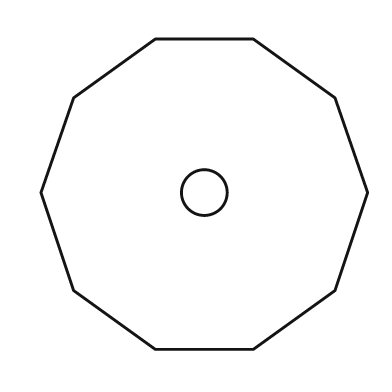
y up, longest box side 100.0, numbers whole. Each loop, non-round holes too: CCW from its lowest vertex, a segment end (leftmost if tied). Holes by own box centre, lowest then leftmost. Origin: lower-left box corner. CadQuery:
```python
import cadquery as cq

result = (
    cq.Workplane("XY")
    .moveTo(35.0, 0.0)
    .lineTo(65.0, 0.0)
    .lineTo(90.0, 18.0)
    .lineTo(100.0, 48.0)
    .lineTo(90.0, 77.0)
    .lineTo(65.0, 95.0)
    .lineTo(35.0, 95.0)
    .lineTo(10.0, 77.0)
    .lineTo(0.0, 48.0)
    .lineTo(10.0, 18.0)
    .close()
    .moveTo(50.0, 48.0)
    .circle(7.0)
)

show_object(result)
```